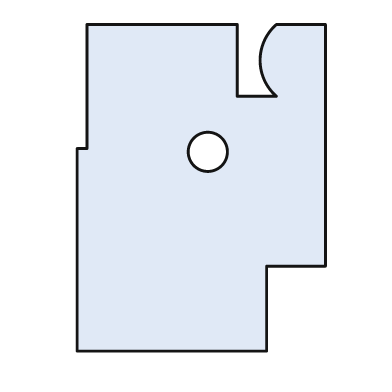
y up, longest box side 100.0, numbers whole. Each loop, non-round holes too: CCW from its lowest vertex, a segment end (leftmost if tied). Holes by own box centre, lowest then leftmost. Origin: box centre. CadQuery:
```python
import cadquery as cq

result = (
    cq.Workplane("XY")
    .moveTo(-38.0, -50.0)
    .lineTo(20.0, -50.0)
    .lineTo(20.0, -24.0)
    .lineTo(38.0, -24.0)
    .lineTo(38.0, 50.0)
    .lineTo(23.0, 50.0)
    .threePointArc((18.0, 39.0), (23.0, 28.0))
    .lineTo(11.0, 28.0)
    .lineTo(11.0, 50.0)
    .lineTo(-35.0, 50.0)
    .lineTo(-35.0, 12.0)
    .lineTo(-38.0, 12.0)
    .close()
    .moveTo(2.0, 11.0)
    .circle(6.0)
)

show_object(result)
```